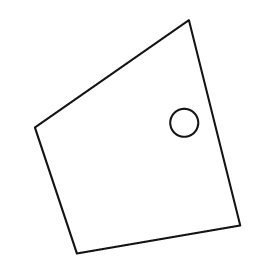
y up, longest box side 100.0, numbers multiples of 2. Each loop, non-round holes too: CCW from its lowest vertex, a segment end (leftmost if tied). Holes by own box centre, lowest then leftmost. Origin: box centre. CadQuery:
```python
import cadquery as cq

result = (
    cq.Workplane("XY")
    .moveTo(-26.0, -50.0)
    .lineTo(44.0, -38.0)
    .lineTo(22.0, 50.0)
    .lineTo(-44.0, 4.0)
    .close()
    .moveTo(20.0, 6.0)
    .circle(6.0)
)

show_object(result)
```